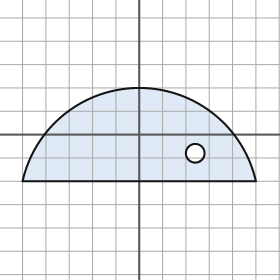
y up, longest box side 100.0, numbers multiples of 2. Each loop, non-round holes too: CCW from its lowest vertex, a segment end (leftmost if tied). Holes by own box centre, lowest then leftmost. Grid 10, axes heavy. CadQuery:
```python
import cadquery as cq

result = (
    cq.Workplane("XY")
    .moveTo(-50.0, -20.0)
    .lineTo(50.0, -20.0)
    .threePointArc((0.0, 20.0), (-50.0, -20.0))
    .close()
    .moveTo(24.0, -8.0)
    .circle(4.0)
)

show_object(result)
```